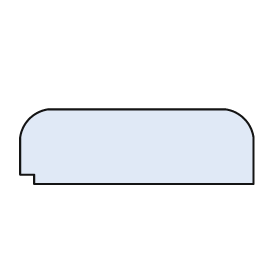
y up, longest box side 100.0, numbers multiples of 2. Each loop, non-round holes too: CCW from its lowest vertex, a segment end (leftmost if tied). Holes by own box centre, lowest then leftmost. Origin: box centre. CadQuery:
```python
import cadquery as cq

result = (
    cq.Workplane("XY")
    .moveTo(-44.0, -16.0)
    .lineTo(50.0, -16.0)
    .lineTo(50.0, 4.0)
    .threePointArc((46.0, 12.0), (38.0, 16.0))
    .lineTo(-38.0, 16.0)
    .threePointArc((-46.0, 12.0), (-50.0, 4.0))
    .lineTo(-50.0, -12.0)
    .lineTo(-44.0, -12.0)
    .close()
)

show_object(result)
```